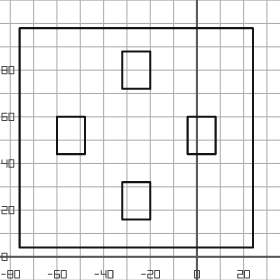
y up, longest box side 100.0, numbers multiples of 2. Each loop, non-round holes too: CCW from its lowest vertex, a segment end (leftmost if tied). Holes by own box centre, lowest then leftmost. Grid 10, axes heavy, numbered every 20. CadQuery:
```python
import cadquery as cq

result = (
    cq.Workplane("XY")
    .moveTo(-76.0, 4.0)
    .lineTo(24.0, 4.0)
    .lineTo(24.0, 98.0)
    .lineTo(-76.0, 98.0)
    .close()
    .moveTo(-32.0, 16.0)
    .lineTo(-20.0, 16.0)
    .lineTo(-20.0, 32.0)
    .lineTo(-32.0, 32.0)
    .close()
    .moveTo(-60.0, 44.0)
    .lineTo(-48.0, 44.0)
    .lineTo(-48.0, 60.0)
    .lineTo(-60.0, 60.0)
    .close()
    .moveTo(-4.0, 44.0)
    .lineTo(8.0, 44.0)
    .lineTo(8.0, 60.0)
    .lineTo(-4.0, 60.0)
    .close()
    .moveTo(-32.0, 72.0)
    .lineTo(-20.0, 72.0)
    .lineTo(-20.0, 88.0)
    .lineTo(-32.0, 88.0)
    .close()
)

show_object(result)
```